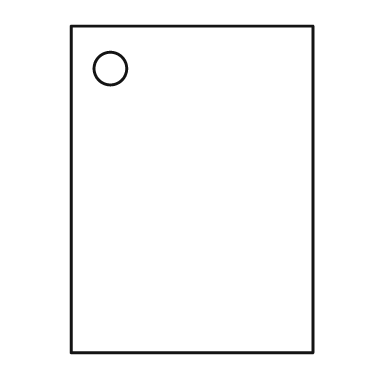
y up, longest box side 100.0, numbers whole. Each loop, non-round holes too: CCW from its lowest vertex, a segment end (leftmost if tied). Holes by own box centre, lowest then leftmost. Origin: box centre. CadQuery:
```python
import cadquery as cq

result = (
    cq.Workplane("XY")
    .moveTo(-37.0, -50.0)
    .lineTo(37.0, -50.0)
    .lineTo(37.0, 50.0)
    .lineTo(-37.0, 50.0)
    .close()
    .moveTo(-25.0, 37.0)
    .circle(5.0)
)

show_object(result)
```